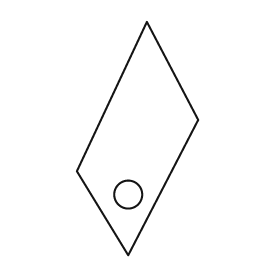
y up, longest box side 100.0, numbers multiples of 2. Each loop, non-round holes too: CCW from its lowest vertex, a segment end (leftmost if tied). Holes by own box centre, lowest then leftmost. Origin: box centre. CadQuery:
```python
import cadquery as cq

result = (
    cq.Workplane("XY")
    .moveTo(-4.0, -50.0)
    .lineTo(26.0, 8.0)
    .lineTo(4.0, 50.0)
    .lineTo(-26.0, -14.0)
    .close()
    .moveTo(-4.0, -24.0)
    .circle(6.0)
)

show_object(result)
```